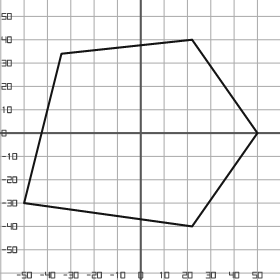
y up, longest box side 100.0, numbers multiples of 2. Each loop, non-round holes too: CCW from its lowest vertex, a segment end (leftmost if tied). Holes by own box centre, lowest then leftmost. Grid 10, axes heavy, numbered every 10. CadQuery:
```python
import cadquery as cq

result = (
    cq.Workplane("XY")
    .moveTo(22.0, -40.0)
    .lineTo(50.0, 0.0)
    .lineTo(22.0, 40.0)
    .lineTo(-34.0, 34.0)
    .lineTo(-50.0, -30.0)
    .close()
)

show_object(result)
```